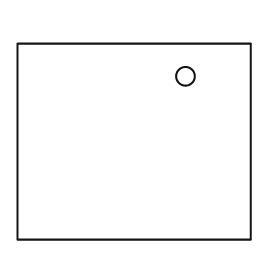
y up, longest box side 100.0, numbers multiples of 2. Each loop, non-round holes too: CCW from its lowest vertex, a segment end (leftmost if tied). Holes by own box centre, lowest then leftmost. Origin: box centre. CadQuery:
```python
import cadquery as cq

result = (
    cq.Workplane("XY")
    .moveTo(-50.0, -42.0)
    .lineTo(50.0, -42.0)
    .lineTo(50.0, 42.0)
    .lineTo(-50.0, 42.0)
    .close()
    .moveTo(22.0, 28.0)
    .circle(4.0)
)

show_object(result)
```